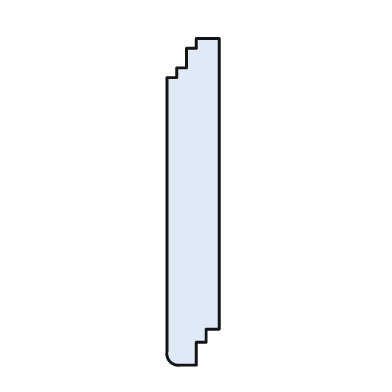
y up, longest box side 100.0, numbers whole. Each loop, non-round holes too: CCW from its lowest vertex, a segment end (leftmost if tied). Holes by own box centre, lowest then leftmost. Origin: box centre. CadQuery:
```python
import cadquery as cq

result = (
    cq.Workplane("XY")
    .moveTo(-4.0, -50.0)
    .lineTo(1.0, -50.0)
    .lineTo(1.0, -43.0)
    .lineTo(4.0, -43.0)
    .lineTo(4.0, -39.0)
    .lineTo(8.0, -39.0)
    .lineTo(8.0, 50.0)
    .lineTo(1.0, 50.0)
    .lineTo(1.0, 47.0)
    .lineTo(-2.0, 47.0)
    .lineTo(-2.0, 41.0)
    .lineTo(-5.0, 41.0)
    .lineTo(-5.0, 38.0)
    .lineTo(-8.0, 38.0)
    .lineTo(-8.0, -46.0)
    .threePointArc((-7.0, -49.0), (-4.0, -50.0))
    .close()
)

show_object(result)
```